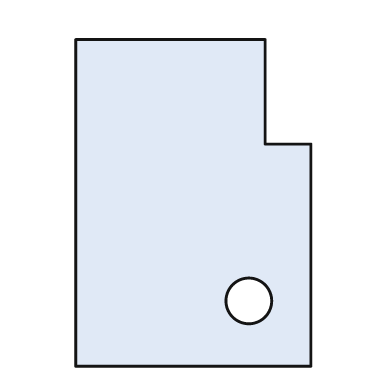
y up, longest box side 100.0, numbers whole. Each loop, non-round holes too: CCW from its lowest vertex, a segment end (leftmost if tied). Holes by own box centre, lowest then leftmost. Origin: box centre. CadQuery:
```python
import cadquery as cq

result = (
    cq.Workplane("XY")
    .moveTo(-36.0, -50.0)
    .lineTo(36.0, -50.0)
    .lineTo(36.0, 18.0)
    .lineTo(22.0, 18.0)
    .lineTo(22.0, 50.0)
    .lineTo(-36.0, 50.0)
    .close()
    .moveTo(17.0, -30.0)
    .circle(7.0)
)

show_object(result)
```